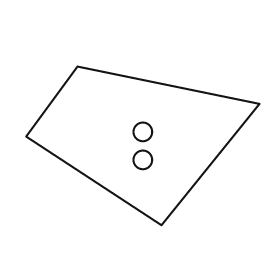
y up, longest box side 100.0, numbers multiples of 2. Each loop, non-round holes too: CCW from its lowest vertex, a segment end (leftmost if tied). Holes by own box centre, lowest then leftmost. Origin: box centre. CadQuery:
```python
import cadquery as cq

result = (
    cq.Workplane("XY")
    .moveTo(8.0, -34.0)
    .lineTo(50.0, 18.0)
    .lineTo(-28.0, 34.0)
    .lineTo(-50.0, 4.0)
    .close()
    .moveTo(0.0, -6.0)
    .circle(4.0)
    .moveTo(0.0, 6.0)
    .circle(4.0)
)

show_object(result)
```